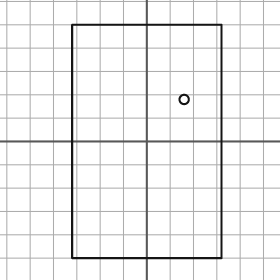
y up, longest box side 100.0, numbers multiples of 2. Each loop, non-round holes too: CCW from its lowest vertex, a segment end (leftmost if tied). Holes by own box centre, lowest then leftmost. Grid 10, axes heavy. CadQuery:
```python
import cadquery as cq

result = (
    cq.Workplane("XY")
    .moveTo(-32.0, -50.0)
    .lineTo(32.0, -50.0)
    .lineTo(32.0, 50.0)
    .lineTo(-32.0, 50.0)
    .close()
    .moveTo(16.0, 18.0)
    .circle(2.0)
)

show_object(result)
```